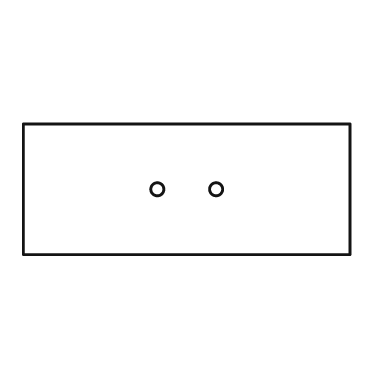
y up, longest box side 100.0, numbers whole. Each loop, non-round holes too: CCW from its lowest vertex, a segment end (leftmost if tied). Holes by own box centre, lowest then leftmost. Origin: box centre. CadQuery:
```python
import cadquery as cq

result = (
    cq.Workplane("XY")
    .moveTo(-50.0, -20.0)
    .lineTo(50.0, -20.0)
    .lineTo(50.0, 20.0)
    .lineTo(-50.0, 20.0)
    .close()
    .moveTo(-9.0, 0.0)
    .circle(2.0)
    .moveTo(9.0, 0.0)
    .circle(2.0)
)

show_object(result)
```